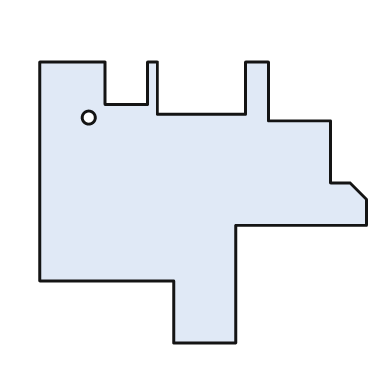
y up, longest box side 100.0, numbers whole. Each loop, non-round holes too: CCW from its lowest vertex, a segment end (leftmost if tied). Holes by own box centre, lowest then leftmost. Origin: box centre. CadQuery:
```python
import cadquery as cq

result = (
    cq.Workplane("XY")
    .moveTo(-9.0, -43.0)
    .lineTo(10.0, -43.0)
    .lineTo(10.0, -7.0)
    .lineTo(50.0, -7.0)
    .lineTo(50.0, 1.0)
    .lineTo(45.0, 6.0)
    .lineTo(39.0, 6.0)
    .lineTo(39.0, 25.0)
    .lineTo(20.0, 25.0)
    .lineTo(20.0, 43.0)
    .lineTo(13.0, 43.0)
    .lineTo(13.0, 27.0)
    .lineTo(-14.0, 27.0)
    .lineTo(-14.0, 43.0)
    .lineTo(-17.0, 43.0)
    .lineTo(-17.0, 30.0)
    .lineTo(-30.0, 30.0)
    .lineTo(-30.0, 43.0)
    .lineTo(-50.0, 43.0)
    .lineTo(-50.0, -24.0)
    .lineTo(-9.0, -24.0)
    .close()
    .moveTo(-35.0, 26.0)
    .circle(2.0)
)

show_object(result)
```